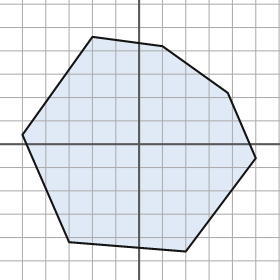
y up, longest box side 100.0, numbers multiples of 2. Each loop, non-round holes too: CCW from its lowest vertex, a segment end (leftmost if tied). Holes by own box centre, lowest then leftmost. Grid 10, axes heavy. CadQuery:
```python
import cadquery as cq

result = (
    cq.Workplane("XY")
    .moveTo(20.0, -46.0)
    .lineTo(50.0, -6.0)
    .lineTo(38.0, 22.0)
    .lineTo(10.0, 42.0)
    .lineTo(-20.0, 46.0)
    .lineTo(-50.0, 4.0)
    .lineTo(-30.0, -42.0)
    .close()
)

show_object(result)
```